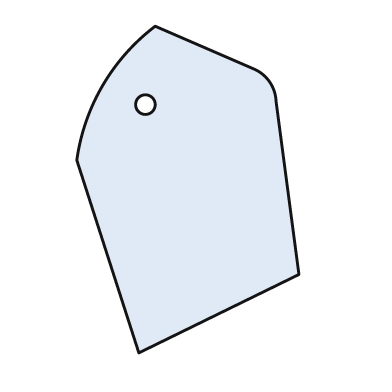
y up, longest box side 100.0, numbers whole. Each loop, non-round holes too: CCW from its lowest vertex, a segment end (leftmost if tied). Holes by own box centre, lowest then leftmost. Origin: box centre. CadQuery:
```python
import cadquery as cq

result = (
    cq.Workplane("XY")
    .moveTo(-15.0, -50.0)
    .lineTo(34.0, -26.0)
    .lineTo(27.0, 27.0)
    .threePointArc((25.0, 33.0), (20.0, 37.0))
    .lineTo(-10.0, 50.0)
    .threePointArc((-26.0, 32.0), (-34.0, 9.0))
    .close()
    .moveTo(-13.0, 26.0)
    .circle(3.0)
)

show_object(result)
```